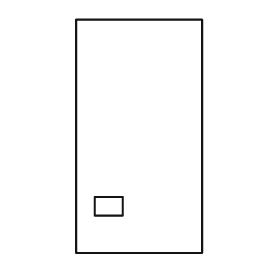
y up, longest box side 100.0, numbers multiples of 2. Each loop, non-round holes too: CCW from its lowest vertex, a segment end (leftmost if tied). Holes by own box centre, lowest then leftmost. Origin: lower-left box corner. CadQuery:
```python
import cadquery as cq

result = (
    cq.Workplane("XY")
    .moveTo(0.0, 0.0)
    .lineTo(54.0, 0.0)
    .lineTo(54.0, 100.0)
    .lineTo(0.0, 100.0)
    .close()
    .moveTo(8.0, 16.0)
    .lineTo(20.0, 16.0)
    .lineTo(20.0, 24.0)
    .lineTo(8.0, 24.0)
    .close()
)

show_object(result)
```